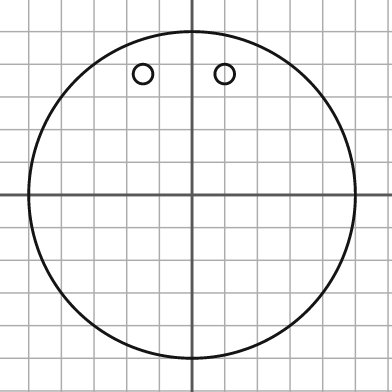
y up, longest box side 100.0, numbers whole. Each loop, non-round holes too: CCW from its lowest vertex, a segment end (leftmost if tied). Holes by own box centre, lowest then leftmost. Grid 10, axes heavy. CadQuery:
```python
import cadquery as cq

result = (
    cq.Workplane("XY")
    .moveTo(0.0, 0.0)
    .circle(50.0)
    .moveTo(-15.0, 37.0)
    .circle(3.0)
    .moveTo(10.0, 37.0)
    .circle(3.0)
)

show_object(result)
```